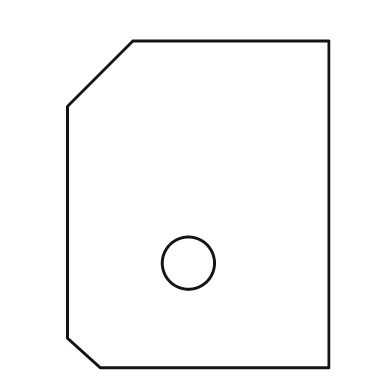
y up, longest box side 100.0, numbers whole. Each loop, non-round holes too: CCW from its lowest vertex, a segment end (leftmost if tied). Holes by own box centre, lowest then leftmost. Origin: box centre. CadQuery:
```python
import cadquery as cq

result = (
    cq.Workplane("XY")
    .moveTo(-30.0, -50.0)
    .lineTo(40.0, -50.0)
    .lineTo(40.0, 50.0)
    .lineTo(-20.0, 50.0)
    .lineTo(-40.0, 30.0)
    .lineTo(-40.0, -41.0)
    .close()
    .moveTo(-3.0, -18.0)
    .circle(8.0)
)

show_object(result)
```